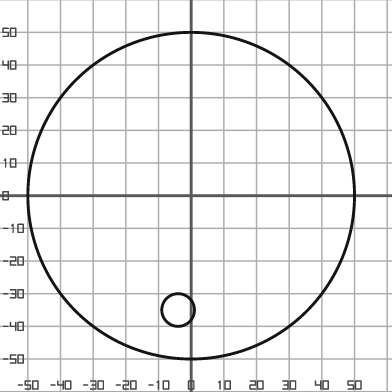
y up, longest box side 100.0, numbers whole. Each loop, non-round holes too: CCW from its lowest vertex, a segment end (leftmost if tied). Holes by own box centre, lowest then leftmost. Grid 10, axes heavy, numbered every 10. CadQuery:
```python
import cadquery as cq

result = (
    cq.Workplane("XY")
    .moveTo(0.0, 0.0)
    .circle(50.0)
    .moveTo(-4.0, -35.0)
    .circle(5.0)
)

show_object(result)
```